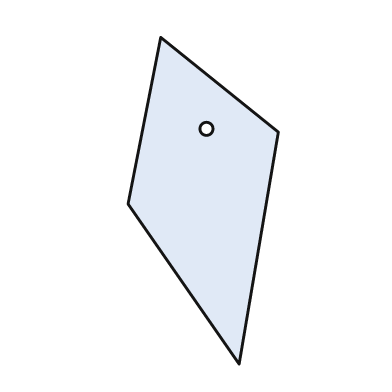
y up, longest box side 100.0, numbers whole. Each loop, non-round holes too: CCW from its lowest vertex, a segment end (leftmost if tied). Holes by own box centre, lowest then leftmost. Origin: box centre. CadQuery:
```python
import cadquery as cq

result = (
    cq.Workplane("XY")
    .moveTo(11.0, -50.0)
    .lineTo(23.0, 21.0)
    .lineTo(-13.0, 50.0)
    .lineTo(-23.0, -1.0)
    .close()
    .moveTo(1.0, 22.0)
    .circle(2.0)
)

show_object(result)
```